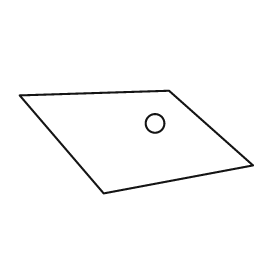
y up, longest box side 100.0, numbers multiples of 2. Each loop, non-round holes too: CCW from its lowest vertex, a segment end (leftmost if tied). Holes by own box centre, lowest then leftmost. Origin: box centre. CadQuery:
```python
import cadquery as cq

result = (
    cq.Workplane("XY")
    .moveTo(-14.0, -22.0)
    .lineTo(50.0, -10.0)
    .lineTo(14.0, 22.0)
    .lineTo(-50.0, 20.0)
    .close()
    .moveTo(8.0, 8.0)
    .circle(4.0)
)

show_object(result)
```